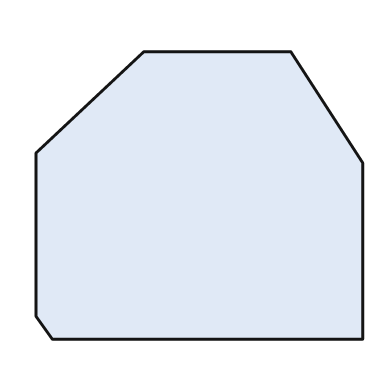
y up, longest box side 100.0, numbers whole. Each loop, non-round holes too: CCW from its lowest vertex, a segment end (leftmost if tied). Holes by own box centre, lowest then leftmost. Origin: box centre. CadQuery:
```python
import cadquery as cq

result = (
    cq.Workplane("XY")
    .moveTo(-45.0, -44.0)
    .lineTo(50.0, -44.0)
    .lineTo(50.0, 10.0)
    .lineTo(28.0, 44.0)
    .lineTo(-17.0, 44.0)
    .lineTo(-50.0, 13.0)
    .lineTo(-50.0, -37.0)
    .close()
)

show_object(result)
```